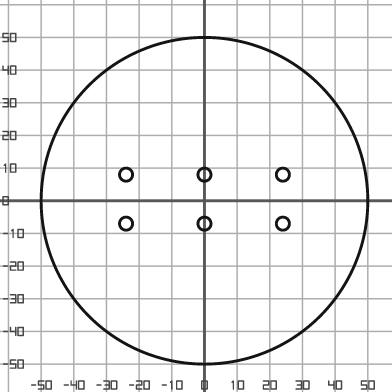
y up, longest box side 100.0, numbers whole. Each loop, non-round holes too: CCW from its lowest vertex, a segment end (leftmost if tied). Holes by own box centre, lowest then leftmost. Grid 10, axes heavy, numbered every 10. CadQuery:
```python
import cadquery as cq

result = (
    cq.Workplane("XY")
    .moveTo(0.0, 0.0)
    .circle(50.0)
    .moveTo(-24.0, -7.0)
    .circle(2.0)
    .moveTo(0.0, -7.0)
    .circle(2.0)
    .moveTo(24.0, -7.0)
    .circle(2.0)
    .moveTo(-24.0, 8.0)
    .circle(2.0)
    .moveTo(0.0, 8.0)
    .circle(2.0)
    .moveTo(24.0, 8.0)
    .circle(2.0)
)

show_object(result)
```